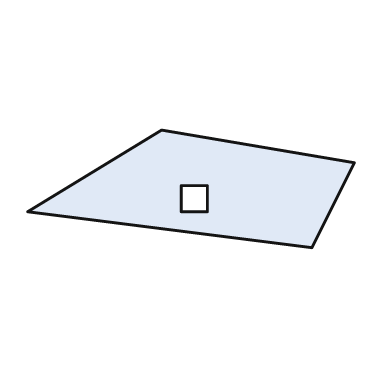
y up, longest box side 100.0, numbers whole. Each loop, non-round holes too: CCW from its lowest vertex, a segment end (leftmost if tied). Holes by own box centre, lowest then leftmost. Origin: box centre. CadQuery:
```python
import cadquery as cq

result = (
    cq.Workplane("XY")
    .moveTo(37.0, -18.0)
    .lineTo(50.0, 8.0)
    .lineTo(-9.0, 18.0)
    .lineTo(-50.0, -7.0)
    .close()
    .moveTo(-3.0, -7.0)
    .lineTo(5.0, -7.0)
    .lineTo(5.0, 1.0)
    .lineTo(-3.0, 1.0)
    .close()
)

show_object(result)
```